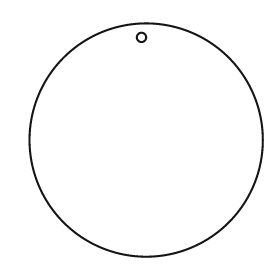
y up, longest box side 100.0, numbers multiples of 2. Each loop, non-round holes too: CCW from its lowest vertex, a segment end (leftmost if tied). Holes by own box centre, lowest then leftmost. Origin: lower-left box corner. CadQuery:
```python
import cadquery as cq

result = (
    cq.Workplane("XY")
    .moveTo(50.0, 50.0)
    .circle(50.0)
    .moveTo(48.0, 94.0)
    .circle(2.0)
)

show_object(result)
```